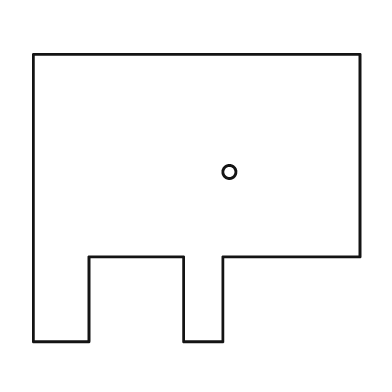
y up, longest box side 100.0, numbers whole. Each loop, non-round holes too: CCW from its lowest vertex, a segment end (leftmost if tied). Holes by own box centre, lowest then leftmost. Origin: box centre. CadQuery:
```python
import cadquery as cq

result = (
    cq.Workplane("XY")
    .moveTo(-50.0, -44.0)
    .lineTo(-33.0, -44.0)
    .lineTo(-33.0, -18.0)
    .lineTo(-4.0, -18.0)
    .lineTo(-4.0, -44.0)
    .lineTo(8.0, -44.0)
    .lineTo(8.0, -18.0)
    .lineTo(50.0, -18.0)
    .lineTo(50.0, 44.0)
    .lineTo(-50.0, 44.0)
    .close()
    .moveTo(10.0, 8.0)
    .circle(2.0)
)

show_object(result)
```